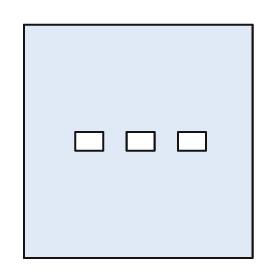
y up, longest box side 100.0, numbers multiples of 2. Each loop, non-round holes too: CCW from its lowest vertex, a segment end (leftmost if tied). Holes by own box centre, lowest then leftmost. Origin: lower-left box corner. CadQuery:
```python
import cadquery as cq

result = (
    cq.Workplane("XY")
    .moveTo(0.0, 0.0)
    .lineTo(98.0, 0.0)
    .lineTo(98.0, 100.0)
    .lineTo(0.0, 100.0)
    .close()
    .moveTo(22.0, 46.0)
    .lineTo(34.0, 46.0)
    .lineTo(34.0, 54.0)
    .lineTo(22.0, 54.0)
    .close()
    .moveTo(44.0, 46.0)
    .lineTo(56.0, 46.0)
    .lineTo(56.0, 54.0)
    .lineTo(44.0, 54.0)
    .close()
    .moveTo(66.0, 46.0)
    .lineTo(78.0, 46.0)
    .lineTo(78.0, 54.0)
    .lineTo(66.0, 54.0)
    .close()
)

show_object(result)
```